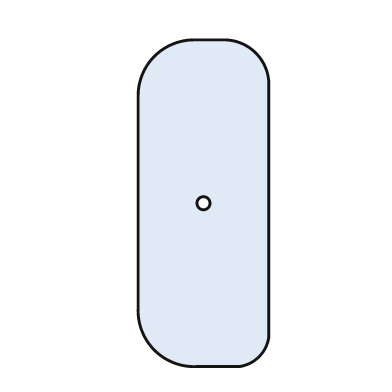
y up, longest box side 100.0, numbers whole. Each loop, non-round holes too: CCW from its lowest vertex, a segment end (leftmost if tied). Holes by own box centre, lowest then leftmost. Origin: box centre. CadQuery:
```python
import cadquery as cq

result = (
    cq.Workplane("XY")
    .moveTo(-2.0, -50.0)
    .lineTo(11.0, -50.0)
    .threePointArc((17.0, -47.0), (20.0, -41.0))
    .lineTo(20.0, 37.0)
    .threePointArc((16.0, 46.0), (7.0, 50.0))
    .lineTo(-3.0, 50.0)
    .threePointArc((-15.0, 45.0), (-20.0, 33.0))
    .lineTo(-20.0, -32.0)
    .threePointArc((-15.0, -45.0), (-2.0, -50.0))
    .close()
    .moveTo(0.0, 0.0)
    .circle(2.0)
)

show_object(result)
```